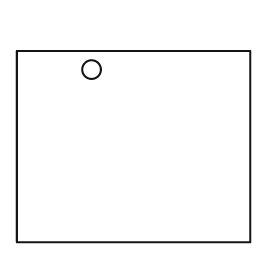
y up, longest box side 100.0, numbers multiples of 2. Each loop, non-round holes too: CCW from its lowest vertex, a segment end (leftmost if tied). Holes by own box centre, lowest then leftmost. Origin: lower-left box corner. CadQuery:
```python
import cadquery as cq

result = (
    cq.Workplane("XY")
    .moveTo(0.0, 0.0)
    .lineTo(100.0, 0.0)
    .lineTo(100.0, 82.0)
    .lineTo(0.0, 82.0)
    .close()
    .moveTo(32.0, 74.0)
    .circle(4.0)
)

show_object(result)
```